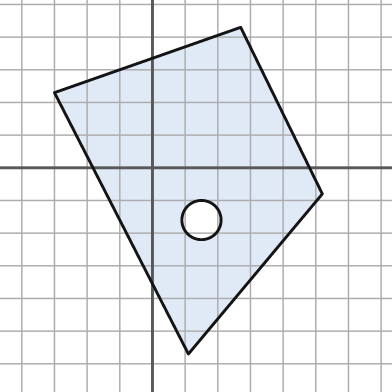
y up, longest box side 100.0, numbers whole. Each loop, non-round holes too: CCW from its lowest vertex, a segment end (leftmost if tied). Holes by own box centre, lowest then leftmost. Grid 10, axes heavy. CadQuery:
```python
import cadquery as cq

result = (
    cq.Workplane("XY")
    .moveTo(11.0, -57.0)
    .lineTo(52.0, -8.0)
    .lineTo(27.0, 43.0)
    .lineTo(-30.0, 23.0)
    .close()
    .moveTo(15.0, -16.0)
    .circle(6.0)
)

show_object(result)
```